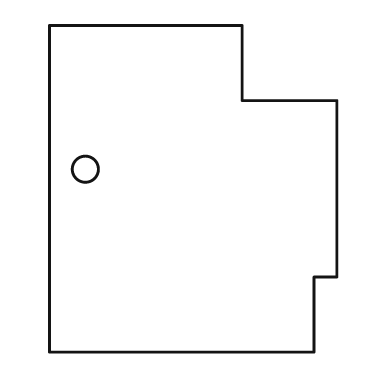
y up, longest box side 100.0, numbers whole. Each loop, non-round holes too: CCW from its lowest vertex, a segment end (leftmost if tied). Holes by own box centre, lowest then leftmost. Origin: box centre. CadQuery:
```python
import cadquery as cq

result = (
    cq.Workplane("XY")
    .moveTo(-44.0, -50.0)
    .lineTo(37.0, -50.0)
    .lineTo(37.0, -27.0)
    .lineTo(44.0, -27.0)
    .lineTo(44.0, 27.0)
    .lineTo(15.0, 27.0)
    .lineTo(15.0, 50.0)
    .lineTo(-44.0, 50.0)
    .close()
    .moveTo(-33.0, 6.0)
    .circle(4.0)
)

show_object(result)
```